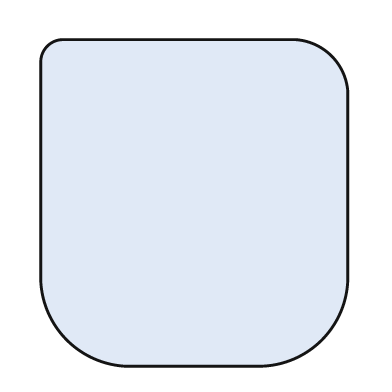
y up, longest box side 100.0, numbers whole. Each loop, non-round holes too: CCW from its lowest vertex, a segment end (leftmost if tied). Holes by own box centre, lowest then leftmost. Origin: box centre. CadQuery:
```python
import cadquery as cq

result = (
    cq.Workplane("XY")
    .moveTo(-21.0, -50.0)
    .lineTo(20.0, -50.0)
    .threePointArc((39.0, -42.0), (47.0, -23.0))
    .lineTo(47.0, 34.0)
    .threePointArc((42.0, 45.0), (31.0, 50.0))
    .lineTo(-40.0, 50.0)
    .threePointArc((-45.0, 48.0), (-47.0, 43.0))
    .lineTo(-47.0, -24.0)
    .threePointArc((-39.0, -42.0), (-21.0, -50.0))
    .close()
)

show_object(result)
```